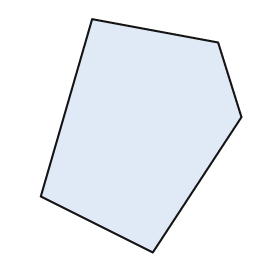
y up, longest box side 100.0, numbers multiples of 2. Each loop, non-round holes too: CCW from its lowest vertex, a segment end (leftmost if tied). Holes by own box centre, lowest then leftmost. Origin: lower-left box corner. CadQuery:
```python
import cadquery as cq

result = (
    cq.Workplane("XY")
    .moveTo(48.0, 0.0)
    .lineTo(86.0, 58.0)
    .lineTo(76.0, 90.0)
    .lineTo(22.0, 100.0)
    .lineTo(0.0, 24.0)
    .close()
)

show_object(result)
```